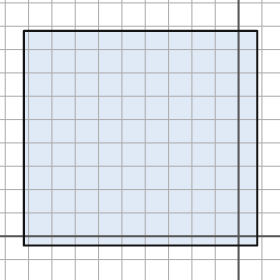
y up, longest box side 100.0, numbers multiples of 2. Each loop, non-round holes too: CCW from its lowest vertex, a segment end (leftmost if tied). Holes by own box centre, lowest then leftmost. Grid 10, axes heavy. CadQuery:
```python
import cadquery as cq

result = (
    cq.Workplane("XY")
    .moveTo(-92.0, -4.0)
    .lineTo(8.0, -4.0)
    .lineTo(8.0, 88.0)
    .lineTo(-92.0, 88.0)
    .close()
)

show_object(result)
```